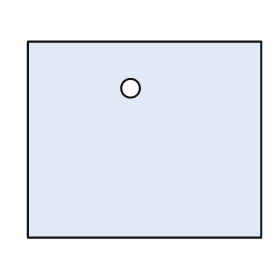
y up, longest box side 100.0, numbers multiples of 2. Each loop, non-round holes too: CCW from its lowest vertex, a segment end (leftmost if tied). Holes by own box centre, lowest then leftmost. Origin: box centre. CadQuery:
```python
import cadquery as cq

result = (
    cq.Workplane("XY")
    .moveTo(-50.0, -42.0)
    .lineTo(50.0, -42.0)
    .lineTo(50.0, 42.0)
    .lineTo(-50.0, 42.0)
    .close()
    .moveTo(-6.0, 22.0)
    .circle(4.0)
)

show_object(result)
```